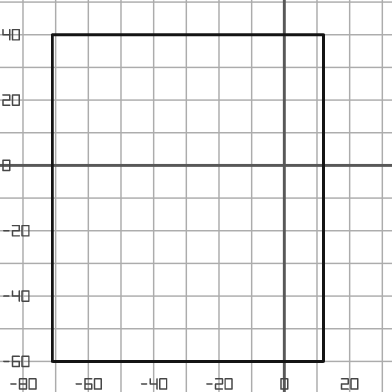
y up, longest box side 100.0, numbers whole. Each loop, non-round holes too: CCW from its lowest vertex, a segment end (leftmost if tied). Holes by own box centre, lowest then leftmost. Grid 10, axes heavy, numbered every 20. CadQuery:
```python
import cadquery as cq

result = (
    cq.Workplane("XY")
    .moveTo(-71.0, -60.0)
    .lineTo(12.0, -60.0)
    .lineTo(12.0, 40.0)
    .lineTo(-71.0, 40.0)
    .close()
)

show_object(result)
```